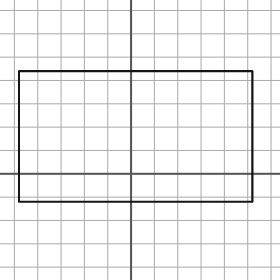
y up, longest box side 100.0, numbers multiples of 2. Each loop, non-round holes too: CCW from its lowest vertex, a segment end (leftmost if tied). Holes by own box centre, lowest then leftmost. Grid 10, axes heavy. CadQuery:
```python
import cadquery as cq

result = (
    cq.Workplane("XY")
    .moveTo(-48.0, -12.0)
    .lineTo(52.0, -12.0)
    .lineTo(52.0, 44.0)
    .lineTo(-48.0, 44.0)
    .close()
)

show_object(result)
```